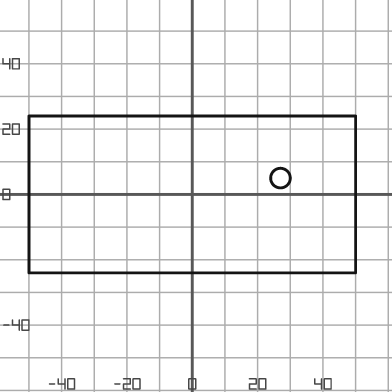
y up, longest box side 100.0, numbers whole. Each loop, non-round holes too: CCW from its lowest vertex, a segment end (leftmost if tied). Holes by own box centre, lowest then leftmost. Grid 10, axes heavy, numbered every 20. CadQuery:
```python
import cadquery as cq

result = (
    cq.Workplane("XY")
    .moveTo(-50.0, -24.0)
    .lineTo(50.0, -24.0)
    .lineTo(50.0, 24.0)
    .lineTo(-50.0, 24.0)
    .close()
    .moveTo(27.0, 5.0)
    .circle(3.0)
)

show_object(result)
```